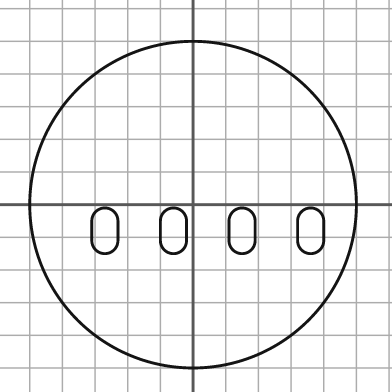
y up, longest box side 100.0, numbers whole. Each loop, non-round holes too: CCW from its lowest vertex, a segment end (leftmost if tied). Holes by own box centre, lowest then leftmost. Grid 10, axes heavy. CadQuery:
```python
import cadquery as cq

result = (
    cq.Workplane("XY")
    .moveTo(0.0, 0.0)
    .circle(50.0)
    .moveTo(-31.0, -11.0)
    .threePointArc((-27.0, -15.0), (-23.0, -11.0))
    .lineTo(-23.0, -5.0)
    .threePointArc((-27.0, -1.0), (-31.0, -5.0))
    .close()
    .moveTo(-10.0, -11.0)
    .threePointArc((-6.0, -15.0), (-2.0, -11.0))
    .lineTo(-2.0, -5.0)
    .threePointArc((-6.0, -1.0), (-10.0, -5.0))
    .close()
    .moveTo(11.0, -11.0)
    .threePointArc((15.0, -15.0), (19.0, -11.0))
    .lineTo(19.0, -5.0)
    .threePointArc((15.0, -1.0), (11.0, -5.0))
    .close()
    .moveTo(32.0, -11.0)
    .threePointArc((36.0, -15.0), (40.0, -11.0))
    .lineTo(40.0, -5.0)
    .threePointArc((36.0, -1.0), (32.0, -5.0))
    .close()
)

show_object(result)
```